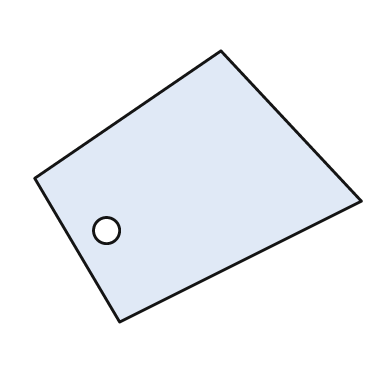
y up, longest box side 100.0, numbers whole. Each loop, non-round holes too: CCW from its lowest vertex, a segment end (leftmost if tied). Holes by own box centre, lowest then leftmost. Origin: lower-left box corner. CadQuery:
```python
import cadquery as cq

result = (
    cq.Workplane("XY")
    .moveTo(26.0, 0.0)
    .lineTo(100.0, 37.0)
    .lineTo(57.0, 83.0)
    .lineTo(0.0, 44.0)
    .close()
    .moveTo(22.0, 28.0)
    .circle(4.0)
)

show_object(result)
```